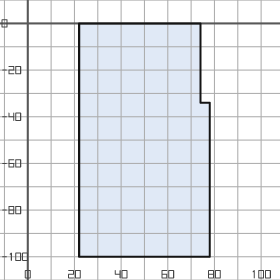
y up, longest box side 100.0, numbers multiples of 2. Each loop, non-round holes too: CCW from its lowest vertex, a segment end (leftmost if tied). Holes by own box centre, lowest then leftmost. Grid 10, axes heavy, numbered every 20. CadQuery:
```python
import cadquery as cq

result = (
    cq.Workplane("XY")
    .moveTo(22.0, -100.0)
    .lineTo(78.0, -100.0)
    .lineTo(78.0, -34.0)
    .lineTo(74.0, -34.0)
    .lineTo(74.0, 0.0)
    .lineTo(22.0, 0.0)
    .close()
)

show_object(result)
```